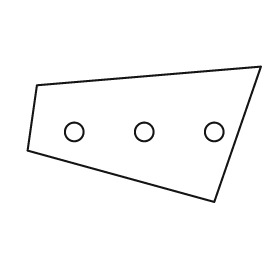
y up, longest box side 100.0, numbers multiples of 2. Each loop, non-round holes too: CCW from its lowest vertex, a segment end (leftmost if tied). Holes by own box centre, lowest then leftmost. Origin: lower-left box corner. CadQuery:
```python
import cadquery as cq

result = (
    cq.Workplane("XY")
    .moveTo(80.0, 0.0)
    .lineTo(100.0, 58.0)
    .lineTo(4.0, 50.0)
    .lineTo(0.0, 22.0)
    .close()
    .moveTo(20.0, 30.0)
    .circle(4.0)
    .moveTo(50.0, 30.0)
    .circle(4.0)
    .moveTo(80.0, 30.0)
    .circle(4.0)
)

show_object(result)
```